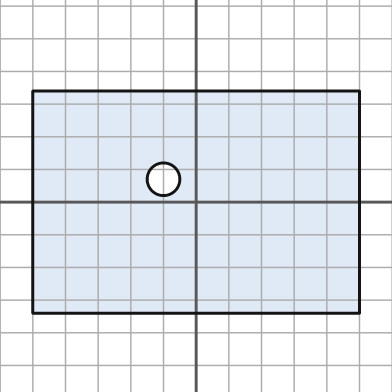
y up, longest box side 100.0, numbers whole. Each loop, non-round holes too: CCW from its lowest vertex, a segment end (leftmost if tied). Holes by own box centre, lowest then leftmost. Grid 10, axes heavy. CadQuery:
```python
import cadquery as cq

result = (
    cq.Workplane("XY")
    .moveTo(-50.0, -34.0)
    .lineTo(50.0, -34.0)
    .lineTo(50.0, 34.0)
    .lineTo(-50.0, 34.0)
    .close()
    .moveTo(-10.0, 7.0)
    .circle(5.0)
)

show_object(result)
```